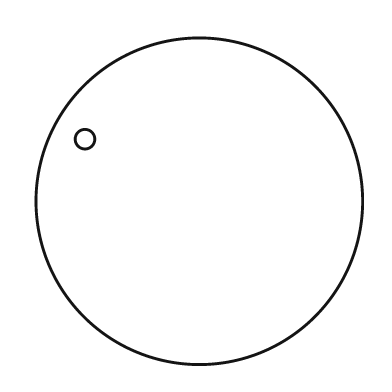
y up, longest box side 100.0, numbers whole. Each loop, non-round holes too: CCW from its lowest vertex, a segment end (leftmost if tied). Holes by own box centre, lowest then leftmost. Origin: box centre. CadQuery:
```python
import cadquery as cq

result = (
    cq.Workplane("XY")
    .moveTo(0.0, 0.0)
    .circle(50.0)
    .moveTo(-35.0, 19.0)
    .circle(3.0)
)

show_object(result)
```